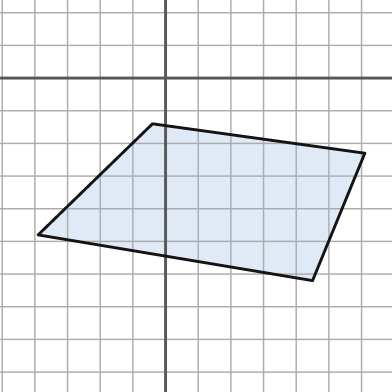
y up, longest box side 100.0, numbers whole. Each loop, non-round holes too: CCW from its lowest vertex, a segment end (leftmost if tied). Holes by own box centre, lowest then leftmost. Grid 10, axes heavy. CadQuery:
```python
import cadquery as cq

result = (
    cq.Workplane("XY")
    .moveTo(45.0, -62.0)
    .lineTo(61.0, -23.0)
    .lineTo(-4.0, -14.0)
    .lineTo(-39.0, -48.0)
    .close()
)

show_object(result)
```